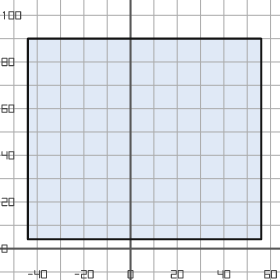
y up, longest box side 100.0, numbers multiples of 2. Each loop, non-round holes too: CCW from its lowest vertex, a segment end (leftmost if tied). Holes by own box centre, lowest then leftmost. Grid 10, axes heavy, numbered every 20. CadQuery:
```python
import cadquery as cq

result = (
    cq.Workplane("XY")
    .moveTo(-44.0, 4.0)
    .lineTo(56.0, 4.0)
    .lineTo(56.0, 90.0)
    .lineTo(-44.0, 90.0)
    .close()
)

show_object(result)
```